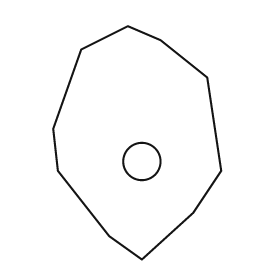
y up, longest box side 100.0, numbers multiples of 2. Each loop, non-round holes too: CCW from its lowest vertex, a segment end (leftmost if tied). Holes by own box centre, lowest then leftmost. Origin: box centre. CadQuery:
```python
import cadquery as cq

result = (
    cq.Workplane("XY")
    .moveTo(2.0, -50.0)
    .lineTo(24.0, -30.0)
    .lineTo(36.0, -12.0)
    .lineTo(30.0, 28.0)
    .lineTo(10.0, 44.0)
    .lineTo(-4.0, 50.0)
    .lineTo(-24.0, 40.0)
    .lineTo(-36.0, 6.0)
    .lineTo(-34.0, -12.0)
    .lineTo(-12.0, -40.0)
    .close()
    .moveTo(2.0, -8.0)
    .circle(8.0)
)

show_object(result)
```